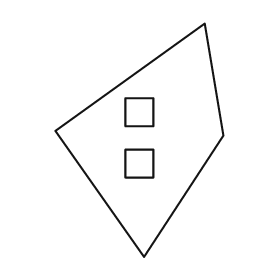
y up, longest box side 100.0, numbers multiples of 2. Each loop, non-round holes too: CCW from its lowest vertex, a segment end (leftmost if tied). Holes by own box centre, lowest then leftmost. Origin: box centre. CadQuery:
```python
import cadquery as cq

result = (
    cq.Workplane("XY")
    .moveTo(2.0, -50.0)
    .lineTo(36.0, 2.0)
    .lineTo(28.0, 50.0)
    .lineTo(-36.0, 4.0)
    .close()
    .moveTo(-6.0, -16.0)
    .lineTo(6.0, -16.0)
    .lineTo(6.0, -4.0)
    .lineTo(-6.0, -4.0)
    .close()
    .moveTo(-6.0, 6.0)
    .lineTo(6.0, 6.0)
    .lineTo(6.0, 18.0)
    .lineTo(-6.0, 18.0)
    .close()
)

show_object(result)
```